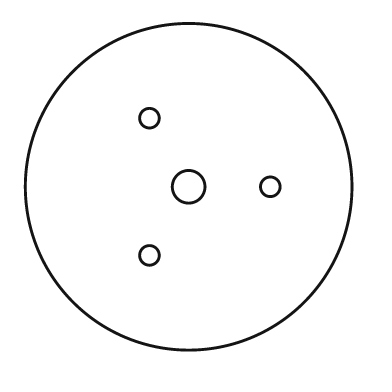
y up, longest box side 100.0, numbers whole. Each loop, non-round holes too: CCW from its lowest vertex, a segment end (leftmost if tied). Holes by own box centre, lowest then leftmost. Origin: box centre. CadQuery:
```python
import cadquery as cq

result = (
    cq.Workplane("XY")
    .moveTo(0.0, 0.0)
    .circle(50.0)
    .moveTo(-12.0, -21.0)
    .circle(3.0)
    .moveTo(0.0, 0.0)
    .circle(5.0)
    .moveTo(25.0, 0.0)
    .circle(3.0)
    .moveTo(-12.0, 21.0)
    .circle(3.0)
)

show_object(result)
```